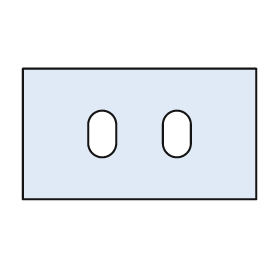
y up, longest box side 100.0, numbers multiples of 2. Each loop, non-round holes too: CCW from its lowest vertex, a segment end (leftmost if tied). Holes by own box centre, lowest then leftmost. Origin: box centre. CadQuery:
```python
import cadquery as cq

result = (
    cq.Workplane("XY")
    .moveTo(-50.0, -28.0)
    .lineTo(50.0, -28.0)
    .lineTo(50.0, 28.0)
    .lineTo(-50.0, 28.0)
    .close()
    .moveTo(-22.0, -4.0)
    .threePointArc((-16.0, -10.0), (-10.0, -4.0))
    .lineTo(-10.0, 4.0)
    .threePointArc((-16.0, 10.0), (-22.0, 4.0))
    .close()
    .moveTo(10.0, -4.0)
    .threePointArc((16.0, -10.0), (22.0, -4.0))
    .lineTo(22.0, 4.0)
    .threePointArc((16.0, 10.0), (10.0, 4.0))
    .close()
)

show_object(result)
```